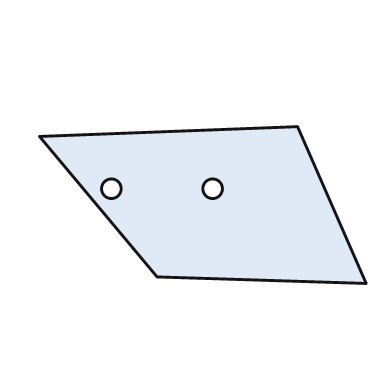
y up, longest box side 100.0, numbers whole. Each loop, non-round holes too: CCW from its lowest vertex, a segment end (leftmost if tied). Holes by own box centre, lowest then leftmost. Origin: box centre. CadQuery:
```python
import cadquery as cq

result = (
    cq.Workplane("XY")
    .moveTo(50.0, -24.0)
    .lineTo(29.0, 24.0)
    .lineTo(-50.0, 21.0)
    .lineTo(-14.0, -22.0)
    .close()
    .moveTo(-28.0, 5.0)
    .circle(3.0)
    .moveTo(3.0, 5.0)
    .circle(3.0)
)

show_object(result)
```